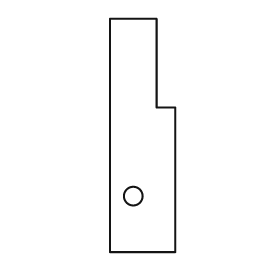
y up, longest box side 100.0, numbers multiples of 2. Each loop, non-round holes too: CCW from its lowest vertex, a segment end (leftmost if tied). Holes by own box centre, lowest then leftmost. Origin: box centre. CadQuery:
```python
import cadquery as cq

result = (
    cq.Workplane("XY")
    .moveTo(-14.0, -50.0)
    .lineTo(14.0, -50.0)
    .lineTo(14.0, 12.0)
    .lineTo(6.0, 12.0)
    .lineTo(6.0, 50.0)
    .lineTo(-14.0, 50.0)
    .close()
    .moveTo(-4.0, -26.0)
    .circle(4.0)
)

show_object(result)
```